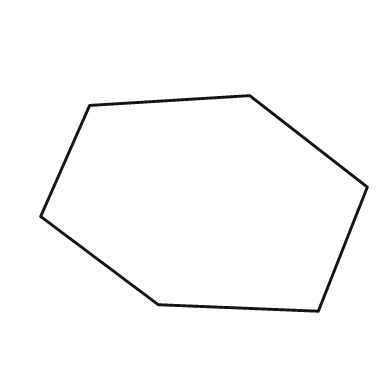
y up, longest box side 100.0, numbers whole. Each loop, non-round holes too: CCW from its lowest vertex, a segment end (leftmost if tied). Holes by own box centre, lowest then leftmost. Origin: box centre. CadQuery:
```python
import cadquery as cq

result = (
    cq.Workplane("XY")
    .moveTo(35.0, -33.0)
    .lineTo(50.0, 5.0)
    .lineTo(14.0, 33.0)
    .lineTo(-35.0, 30.0)
    .lineTo(-50.0, -4.0)
    .lineTo(-14.0, -31.0)
    .close()
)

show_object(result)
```